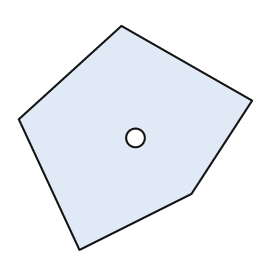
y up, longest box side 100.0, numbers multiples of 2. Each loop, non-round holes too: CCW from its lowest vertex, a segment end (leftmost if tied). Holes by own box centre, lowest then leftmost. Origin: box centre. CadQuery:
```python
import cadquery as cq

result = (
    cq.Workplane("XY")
    .moveTo(-24.0, -48.0)
    .lineTo(24.0, -24.0)
    .lineTo(50.0, 16.0)
    .lineTo(-6.0, 48.0)
    .lineTo(-50.0, 8.0)
    .close()
    .moveTo(0.0, 0.0)
    .circle(4.0)
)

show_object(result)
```